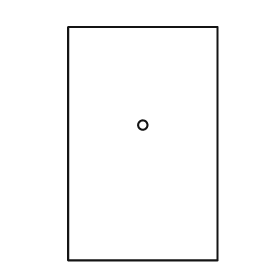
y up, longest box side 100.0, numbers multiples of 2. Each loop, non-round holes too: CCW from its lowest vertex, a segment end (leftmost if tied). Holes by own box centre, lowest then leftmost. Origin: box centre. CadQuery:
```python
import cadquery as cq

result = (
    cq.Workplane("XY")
    .moveTo(-32.0, -50.0)
    .lineTo(32.0, -50.0)
    .lineTo(32.0, 50.0)
    .lineTo(-32.0, 50.0)
    .close()
    .moveTo(0.0, 8.0)
    .circle(2.0)
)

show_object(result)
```